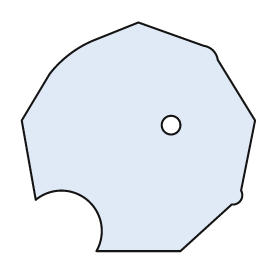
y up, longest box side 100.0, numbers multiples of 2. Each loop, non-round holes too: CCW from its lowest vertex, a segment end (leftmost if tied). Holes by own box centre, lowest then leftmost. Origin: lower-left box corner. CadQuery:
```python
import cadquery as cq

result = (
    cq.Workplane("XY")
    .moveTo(32.0, 0.0)
    .lineTo(68.0, 0.0)
    .lineTo(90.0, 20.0)
    .threePointArc((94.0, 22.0), (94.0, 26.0))
    .lineTo(100.0, 56.0)
    .lineTo(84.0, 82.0)
    .threePointArc((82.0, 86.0), (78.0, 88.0))
    .lineTo(50.0, 98.0)
    .lineTo(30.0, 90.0)
    .threePointArc((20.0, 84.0), (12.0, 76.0))
    .lineTo(0.0, 56.0)
    .lineTo(6.0, 22.0)
    .threePointArc((28.0, 22.0), (32.0, 0.0))
    .close()
    .moveTo(64.0, 54.0)
    .circle(4.0)
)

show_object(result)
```